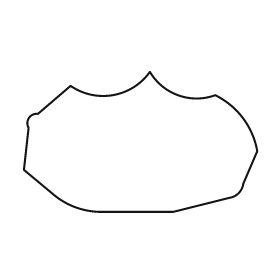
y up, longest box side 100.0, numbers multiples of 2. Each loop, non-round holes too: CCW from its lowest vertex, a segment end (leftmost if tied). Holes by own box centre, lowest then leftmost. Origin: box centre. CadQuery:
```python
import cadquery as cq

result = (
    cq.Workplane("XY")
    .moveTo(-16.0, -30.0)
    .lineTo(14.0, -30.0)
    .lineTo(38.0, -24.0)
    .threePointArc((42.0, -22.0), (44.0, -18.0))
    .lineTo(50.0, -4.0)
    .threePointArc((44.0, 10.0), (32.0, 20.0))
    .threePointArc((16.0, 20.0), (4.0, 30.0))
    .threePointArc((-12.0, 20.0), (-30.0, 24.0))
    .lineTo(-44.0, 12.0)
    .threePointArc((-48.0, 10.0), (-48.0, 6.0))
    .lineTo(-50.0, -12.0)
    .lineTo(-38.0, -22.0)
    .threePointArc((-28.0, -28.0), (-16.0, -30.0))
    .close()
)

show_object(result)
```